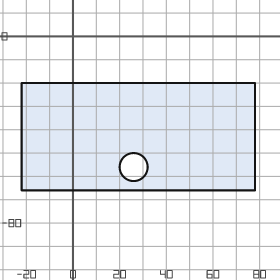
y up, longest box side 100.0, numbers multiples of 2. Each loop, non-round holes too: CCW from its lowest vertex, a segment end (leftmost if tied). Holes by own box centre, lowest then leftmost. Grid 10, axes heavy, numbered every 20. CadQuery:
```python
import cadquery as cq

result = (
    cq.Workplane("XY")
    .moveTo(-22.0, -66.0)
    .lineTo(78.0, -66.0)
    .lineTo(78.0, -20.0)
    .lineTo(-22.0, -20.0)
    .close()
    .moveTo(26.0, -56.0)
    .circle(6.0)
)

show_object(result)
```